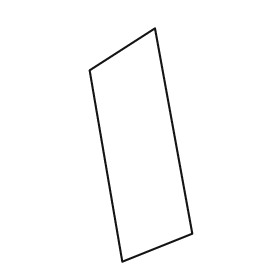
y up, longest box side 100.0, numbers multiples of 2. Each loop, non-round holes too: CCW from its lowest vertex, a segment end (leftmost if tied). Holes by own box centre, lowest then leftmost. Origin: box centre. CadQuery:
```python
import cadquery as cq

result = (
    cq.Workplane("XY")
    .moveTo(-8.0, -50.0)
    .lineTo(22.0, -38.0)
    .lineTo(6.0, 50.0)
    .lineTo(-22.0, 32.0)
    .close()
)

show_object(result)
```